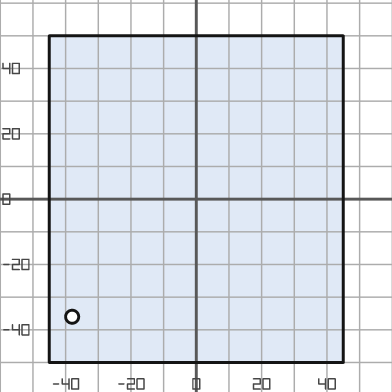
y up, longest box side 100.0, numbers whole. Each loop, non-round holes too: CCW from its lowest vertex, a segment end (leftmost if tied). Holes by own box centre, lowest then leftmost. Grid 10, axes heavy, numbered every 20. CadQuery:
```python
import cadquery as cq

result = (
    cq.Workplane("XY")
    .moveTo(-45.0, -50.0)
    .lineTo(45.0, -50.0)
    .lineTo(45.0, 50.0)
    .lineTo(-45.0, 50.0)
    .close()
    .moveTo(-38.0, -36.0)
    .circle(2.0)
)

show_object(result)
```